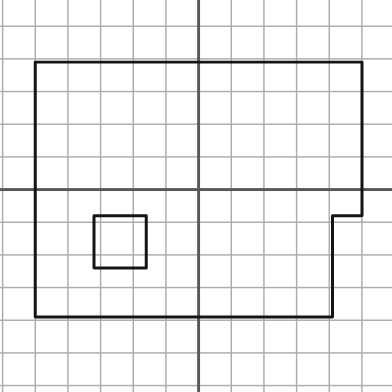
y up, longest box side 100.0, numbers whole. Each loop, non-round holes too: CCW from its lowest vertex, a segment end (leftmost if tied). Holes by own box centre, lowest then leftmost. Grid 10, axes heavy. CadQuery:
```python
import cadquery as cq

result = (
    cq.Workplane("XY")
    .moveTo(-50.0, -39.0)
    .lineTo(41.0, -39.0)
    .lineTo(41.0, -8.0)
    .lineTo(50.0, -8.0)
    .lineTo(50.0, 39.0)
    .lineTo(-50.0, 39.0)
    .close()
    .moveTo(-32.0, -24.0)
    .lineTo(-16.0, -24.0)
    .lineTo(-16.0, -8.0)
    .lineTo(-32.0, -8.0)
    .close()
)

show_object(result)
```